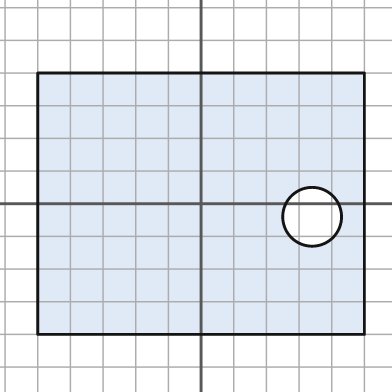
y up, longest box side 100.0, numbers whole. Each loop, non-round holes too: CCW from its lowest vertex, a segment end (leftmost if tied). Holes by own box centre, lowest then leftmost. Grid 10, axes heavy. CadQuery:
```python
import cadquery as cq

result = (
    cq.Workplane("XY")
    .moveTo(-50.0, -40.0)
    .lineTo(50.0, -40.0)
    .lineTo(50.0, 40.0)
    .lineTo(-50.0, 40.0)
    .close()
    .moveTo(34.0, -4.0)
    .circle(9.0)
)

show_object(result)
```